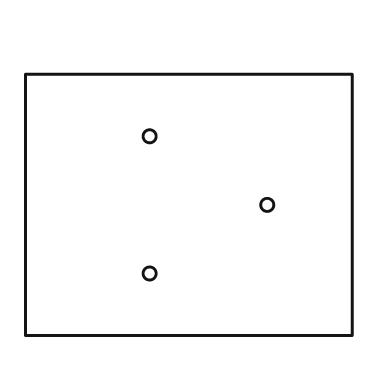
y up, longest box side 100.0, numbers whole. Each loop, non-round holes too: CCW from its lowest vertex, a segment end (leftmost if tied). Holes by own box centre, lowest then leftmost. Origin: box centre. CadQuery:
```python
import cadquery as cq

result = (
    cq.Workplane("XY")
    .moveTo(-50.0, -40.0)
    .lineTo(50.0, -40.0)
    .lineTo(50.0, 40.0)
    .lineTo(-50.0, 40.0)
    .close()
    .moveTo(-12.0, -21.0)
    .circle(2.0)
    .moveTo(24.0, 0.0)
    .circle(2.0)
    .moveTo(-12.0, 21.0)
    .circle(2.0)
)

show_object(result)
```